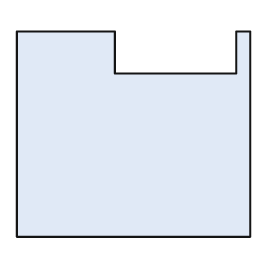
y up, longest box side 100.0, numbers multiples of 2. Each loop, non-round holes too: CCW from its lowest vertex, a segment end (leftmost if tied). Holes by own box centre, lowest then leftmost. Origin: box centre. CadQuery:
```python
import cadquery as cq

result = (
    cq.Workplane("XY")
    .moveTo(-50.0, -44.0)
    .lineTo(50.0, -44.0)
    .lineTo(50.0, 44.0)
    .lineTo(44.0, 44.0)
    .lineTo(44.0, 26.0)
    .lineTo(-8.0, 26.0)
    .lineTo(-8.0, 44.0)
    .lineTo(-50.0, 44.0)
    .close()
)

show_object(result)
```